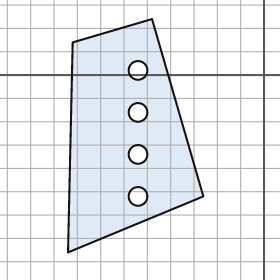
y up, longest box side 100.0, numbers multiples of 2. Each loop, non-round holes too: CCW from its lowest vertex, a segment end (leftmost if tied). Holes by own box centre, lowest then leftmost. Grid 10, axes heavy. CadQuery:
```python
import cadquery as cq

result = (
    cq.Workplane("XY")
    .moveTo(-84.0, -76.0)
    .lineTo(-26.0, -52.0)
    .lineTo(-48.0, 24.0)
    .lineTo(-82.0, 14.0)
    .close()
    .moveTo(-54.0, -52.0)
    .circle(4.0)
    .moveTo(-54.0, -34.0)
    .circle(4.0)
    .moveTo(-54.0, -16.0)
    .circle(4.0)
    .moveTo(-54.0, 2.0)
    .circle(4.0)
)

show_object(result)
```